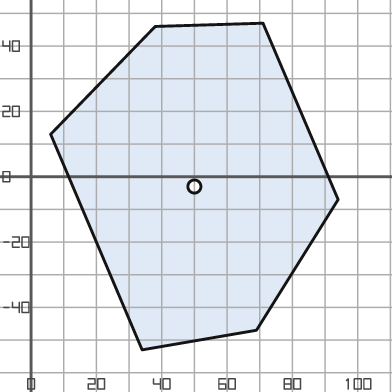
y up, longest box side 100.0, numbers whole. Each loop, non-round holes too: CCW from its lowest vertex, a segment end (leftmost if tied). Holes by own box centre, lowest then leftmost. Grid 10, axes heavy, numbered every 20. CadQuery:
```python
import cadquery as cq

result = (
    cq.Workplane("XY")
    .moveTo(34.0, -53.0)
    .lineTo(69.0, -47.0)
    .lineTo(94.0, -7.0)
    .lineTo(71.0, 47.0)
    .lineTo(38.0, 46.0)
    .lineTo(6.0, 13.0)
    .close()
    .moveTo(50.0, -3.0)
    .circle(2.0)
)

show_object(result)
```